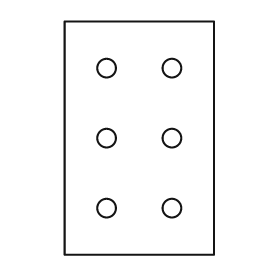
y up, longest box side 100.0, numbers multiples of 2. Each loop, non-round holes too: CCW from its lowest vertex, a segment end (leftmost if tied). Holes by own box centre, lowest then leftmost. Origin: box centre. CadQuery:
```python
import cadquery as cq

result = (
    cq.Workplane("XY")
    .moveTo(-32.0, -50.0)
    .lineTo(32.0, -50.0)
    .lineTo(32.0, 50.0)
    .lineTo(-32.0, 50.0)
    .close()
    .moveTo(-14.0, -30.0)
    .circle(4.0)
    .moveTo(14.0, -30.0)
    .circle(4.0)
    .moveTo(-14.0, 0.0)
    .circle(4.0)
    .moveTo(14.0, 0.0)
    .circle(4.0)
    .moveTo(-14.0, 30.0)
    .circle(4.0)
    .moveTo(14.0, 30.0)
    .circle(4.0)
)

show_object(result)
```